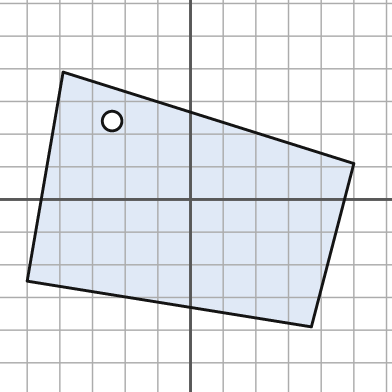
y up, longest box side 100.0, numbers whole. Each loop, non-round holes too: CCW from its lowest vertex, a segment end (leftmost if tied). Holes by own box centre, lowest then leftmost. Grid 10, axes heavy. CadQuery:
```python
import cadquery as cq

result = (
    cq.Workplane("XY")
    .moveTo(37.0, -39.0)
    .lineTo(50.0, 11.0)
    .lineTo(-39.0, 39.0)
    .lineTo(-50.0, -25.0)
    .close()
    .moveTo(-24.0, 24.0)
    .circle(3.0)
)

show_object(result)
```